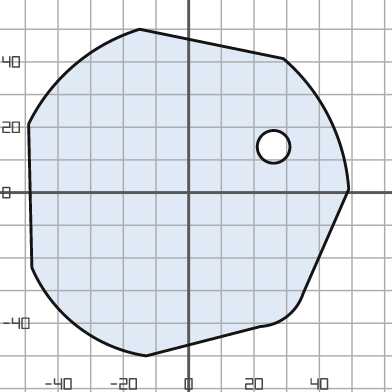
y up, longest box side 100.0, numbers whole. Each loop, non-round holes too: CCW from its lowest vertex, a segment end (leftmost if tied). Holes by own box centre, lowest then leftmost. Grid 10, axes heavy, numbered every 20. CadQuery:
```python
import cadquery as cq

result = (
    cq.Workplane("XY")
    .moveTo(-13.0, -50.0)
    .lineTo(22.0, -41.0)
    .threePointArc((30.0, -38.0), (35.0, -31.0))
    .lineTo(49.0, 1.0)
    .threePointArc((43.0, 23.0), (29.0, 41.0))
    .lineTo(-15.0, 50.0)
    .threePointArc((-35.0, 39.0), (-49.0, 21.0))
    .lineTo(-48.0, -23.0)
    .threePointArc((-34.0, -41.0), (-13.0, -50.0))
    .close()
    .moveTo(26.0, 14.0)
    .circle(5.0)
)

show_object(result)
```